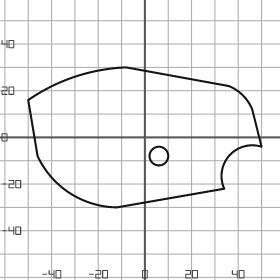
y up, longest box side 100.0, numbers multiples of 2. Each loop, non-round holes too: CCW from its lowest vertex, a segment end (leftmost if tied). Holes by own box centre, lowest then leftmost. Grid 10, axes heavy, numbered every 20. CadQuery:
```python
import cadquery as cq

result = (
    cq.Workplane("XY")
    .moveTo(-12.0, -30.0)
    .lineTo(34.0, -22.0)
    .threePointArc((36.0, -8.0), (50.0, -4.0))
    .lineTo(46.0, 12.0)
    .threePointArc((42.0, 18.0), (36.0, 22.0))
    .lineTo(-8.0, 30.0)
    .threePointArc((-30.0, 26.0), (-50.0, 16.0))
    .lineTo(-46.0, -8.0)
    .threePointArc((-32.0, -24.0), (-12.0, -30.0))
    .close()
    .moveTo(6.0, -8.0)
    .circle(4.0)
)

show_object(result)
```